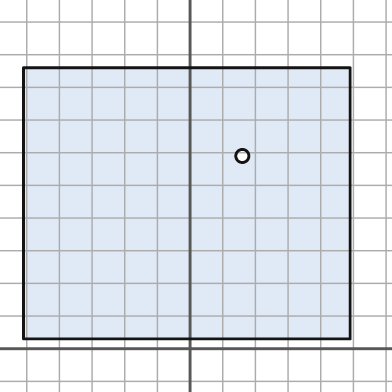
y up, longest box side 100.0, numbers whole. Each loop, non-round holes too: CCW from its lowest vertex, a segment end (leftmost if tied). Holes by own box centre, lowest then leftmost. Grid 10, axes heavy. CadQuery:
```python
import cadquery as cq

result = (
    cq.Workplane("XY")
    .moveTo(-51.0, 3.0)
    .lineTo(49.0, 3.0)
    .lineTo(49.0, 86.0)
    .lineTo(-51.0, 86.0)
    .close()
    .moveTo(16.0, 59.0)
    .circle(2.0)
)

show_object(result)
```